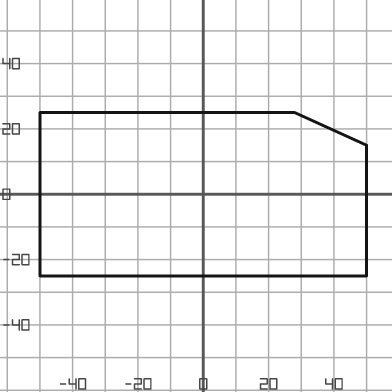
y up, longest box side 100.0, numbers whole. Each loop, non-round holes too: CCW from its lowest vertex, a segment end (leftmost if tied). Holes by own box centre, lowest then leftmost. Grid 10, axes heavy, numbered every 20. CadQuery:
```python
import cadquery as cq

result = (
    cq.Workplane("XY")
    .moveTo(-50.0, -25.0)
    .lineTo(50.0, -25.0)
    .lineTo(50.0, 15.0)
    .lineTo(28.0, 25.0)
    .lineTo(-50.0, 25.0)
    .close()
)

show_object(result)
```